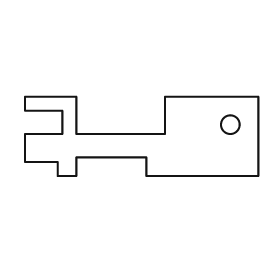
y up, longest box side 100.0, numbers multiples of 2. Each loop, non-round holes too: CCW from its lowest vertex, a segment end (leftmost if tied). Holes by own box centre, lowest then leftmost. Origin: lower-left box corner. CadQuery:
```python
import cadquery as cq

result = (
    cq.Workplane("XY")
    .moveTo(14.0, 0.0)
    .lineTo(22.0, 0.0)
    .lineTo(22.0, 8.0)
    .lineTo(52.0, 8.0)
    .lineTo(52.0, 0.0)
    .lineTo(100.0, 0.0)
    .lineTo(100.0, 34.0)
    .lineTo(60.0, 34.0)
    .lineTo(60.0, 18.0)
    .lineTo(22.0, 18.0)
    .lineTo(22.0, 34.0)
    .lineTo(0.0, 34.0)
    .lineTo(0.0, 28.0)
    .lineTo(16.0, 28.0)
    .lineTo(16.0, 18.0)
    .lineTo(0.0, 18.0)
    .lineTo(0.0, 6.0)
    .lineTo(14.0, 6.0)
    .close()
    .moveTo(88.0, 22.0)
    .circle(4.0)
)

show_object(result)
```